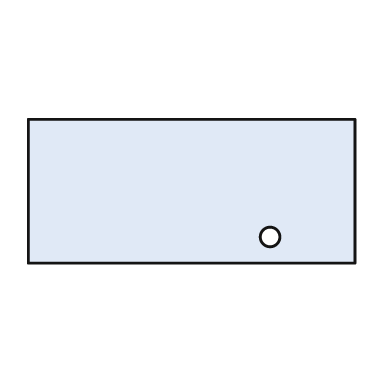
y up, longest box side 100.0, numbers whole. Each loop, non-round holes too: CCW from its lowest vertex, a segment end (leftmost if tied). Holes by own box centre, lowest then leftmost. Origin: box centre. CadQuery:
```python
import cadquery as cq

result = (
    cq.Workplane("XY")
    .moveTo(-50.0, -22.0)
    .lineTo(50.0, -22.0)
    .lineTo(50.0, 22.0)
    .lineTo(-50.0, 22.0)
    .close()
    .moveTo(24.0, -14.0)
    .circle(3.0)
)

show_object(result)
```